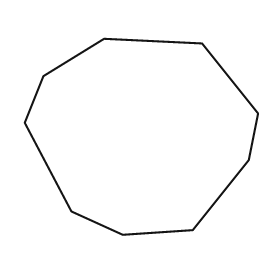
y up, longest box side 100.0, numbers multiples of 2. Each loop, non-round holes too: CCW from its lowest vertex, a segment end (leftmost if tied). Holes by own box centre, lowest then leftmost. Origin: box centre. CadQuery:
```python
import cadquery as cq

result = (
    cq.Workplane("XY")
    .moveTo(-8.0, -42.0)
    .lineTo(22.0, -40.0)
    .lineTo(46.0, -10.0)
    .lineTo(50.0, 10.0)
    .lineTo(26.0, 40.0)
    .lineTo(-16.0, 42.0)
    .lineTo(-42.0, 26.0)
    .lineTo(-50.0, 6.0)
    .lineTo(-30.0, -32.0)
    .close()
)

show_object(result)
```